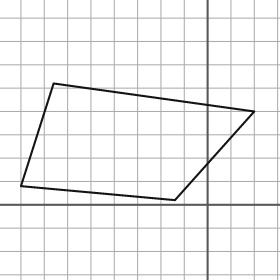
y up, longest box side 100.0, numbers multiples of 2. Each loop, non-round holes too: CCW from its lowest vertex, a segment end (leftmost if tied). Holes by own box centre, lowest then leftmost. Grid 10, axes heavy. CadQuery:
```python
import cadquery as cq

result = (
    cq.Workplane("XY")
    .moveTo(-14.0, 2.0)
    .lineTo(20.0, 40.0)
    .lineTo(-66.0, 52.0)
    .lineTo(-80.0, 8.0)
    .close()
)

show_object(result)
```